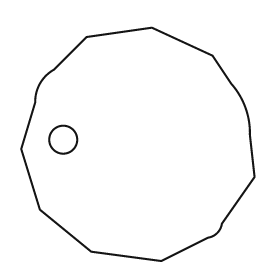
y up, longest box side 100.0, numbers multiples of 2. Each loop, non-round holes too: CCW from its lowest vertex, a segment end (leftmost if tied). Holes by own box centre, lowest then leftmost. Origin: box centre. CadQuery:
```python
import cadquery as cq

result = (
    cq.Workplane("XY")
    .moveTo(10.0, -50.0)
    .lineTo(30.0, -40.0)
    .threePointArc((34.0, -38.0), (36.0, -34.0))
    .lineTo(50.0, -14.0)
    .lineTo(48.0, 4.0)
    .threePointArc((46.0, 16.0), (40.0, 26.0))
    .lineTo(32.0, 38.0)
    .lineTo(6.0, 50.0)
    .lineTo(-22.0, 46.0)
    .lineTo(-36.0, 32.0)
    .threePointArc((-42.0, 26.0), (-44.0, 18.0))
    .lineTo(-50.0, -2.0)
    .lineTo(-42.0, -28.0)
    .lineTo(-20.0, -46.0)
    .close()
    .moveTo(-32.0, 2.0)
    .circle(6.0)
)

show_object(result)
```